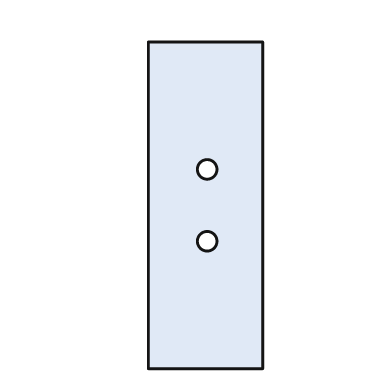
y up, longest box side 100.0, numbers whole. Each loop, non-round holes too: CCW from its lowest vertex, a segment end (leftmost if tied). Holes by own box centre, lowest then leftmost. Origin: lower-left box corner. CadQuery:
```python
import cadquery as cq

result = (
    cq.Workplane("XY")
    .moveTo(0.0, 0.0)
    .lineTo(35.0, 0.0)
    .lineTo(35.0, 100.0)
    .lineTo(0.0, 100.0)
    .close()
    .moveTo(18.0, 39.0)
    .circle(3.0)
    .moveTo(18.0, 61.0)
    .circle(3.0)
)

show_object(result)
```